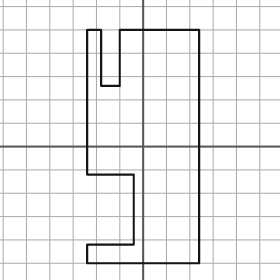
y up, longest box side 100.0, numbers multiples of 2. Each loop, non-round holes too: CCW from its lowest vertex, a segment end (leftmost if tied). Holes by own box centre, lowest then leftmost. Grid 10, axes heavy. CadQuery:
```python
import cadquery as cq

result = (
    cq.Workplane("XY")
    .moveTo(-24.0, -50.0)
    .lineTo(24.0, -50.0)
    .lineTo(24.0, 50.0)
    .lineTo(-10.0, 50.0)
    .lineTo(-10.0, 26.0)
    .lineTo(-18.0, 26.0)
    .lineTo(-18.0, 50.0)
    .lineTo(-24.0, 50.0)
    .lineTo(-24.0, -12.0)
    .lineTo(-4.0, -12.0)
    .lineTo(-4.0, -42.0)
    .lineTo(-24.0, -42.0)
    .close()
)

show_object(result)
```